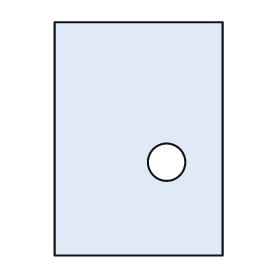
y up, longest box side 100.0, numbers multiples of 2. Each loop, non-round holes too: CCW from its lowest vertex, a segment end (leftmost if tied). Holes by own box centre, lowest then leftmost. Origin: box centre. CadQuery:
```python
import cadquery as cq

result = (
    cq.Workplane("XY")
    .moveTo(-36.0, -50.0)
    .lineTo(36.0, -50.0)
    .lineTo(36.0, 50.0)
    .lineTo(-36.0, 50.0)
    .close()
    .moveTo(12.0, -10.0)
    .circle(8.0)
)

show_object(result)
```